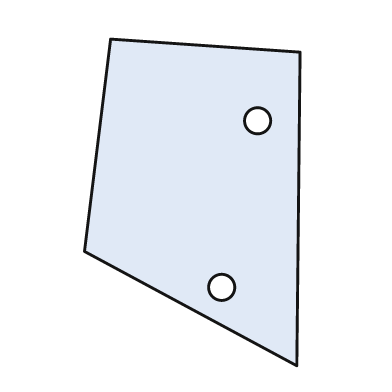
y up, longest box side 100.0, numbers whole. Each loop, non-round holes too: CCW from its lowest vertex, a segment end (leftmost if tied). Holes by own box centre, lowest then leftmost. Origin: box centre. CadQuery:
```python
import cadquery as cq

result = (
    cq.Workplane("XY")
    .moveTo(32.0, -50.0)
    .lineTo(33.0, 46.0)
    .lineTo(-25.0, 50.0)
    .lineTo(-33.0, -15.0)
    .close()
    .moveTo(9.0, -26.0)
    .circle(4.0)
    .moveTo(20.0, 25.0)
    .circle(4.0)
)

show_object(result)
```